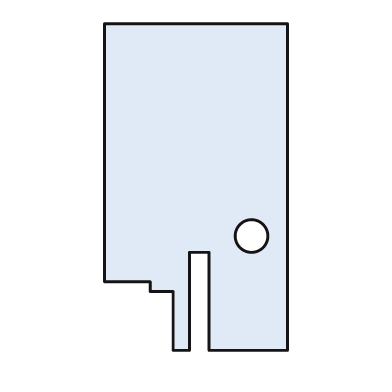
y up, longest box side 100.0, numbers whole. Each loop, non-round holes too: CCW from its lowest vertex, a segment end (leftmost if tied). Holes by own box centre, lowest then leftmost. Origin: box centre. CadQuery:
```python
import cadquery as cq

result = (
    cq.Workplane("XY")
    .moveTo(-7.0, -50.0)
    .lineTo(-2.0, -50.0)
    .lineTo(-2.0, -20.0)
    .lineTo(4.0, -20.0)
    .lineTo(4.0, -50.0)
    .lineTo(28.0, -50.0)
    .lineTo(28.0, 50.0)
    .lineTo(-28.0, 50.0)
    .lineTo(-28.0, -29.0)
    .lineTo(-14.0, -29.0)
    .lineTo(-14.0, -32.0)
    .lineTo(-7.0, -32.0)
    .close()
    .moveTo(17.0, -15.0)
    .circle(5.0)
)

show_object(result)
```